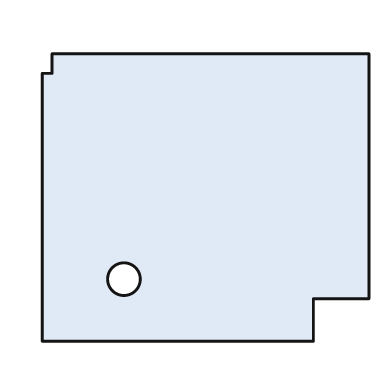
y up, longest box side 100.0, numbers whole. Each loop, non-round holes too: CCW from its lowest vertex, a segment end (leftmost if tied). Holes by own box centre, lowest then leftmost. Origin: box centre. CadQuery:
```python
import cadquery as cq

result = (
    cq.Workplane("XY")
    .moveTo(-50.0, -44.0)
    .lineTo(33.0, -44.0)
    .lineTo(33.0, -31.0)
    .lineTo(50.0, -31.0)
    .lineTo(50.0, 44.0)
    .lineTo(-47.0, 44.0)
    .lineTo(-47.0, 38.0)
    .lineTo(-50.0, 38.0)
    .close()
    .moveTo(-25.0, -25.0)
    .circle(5.0)
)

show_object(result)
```